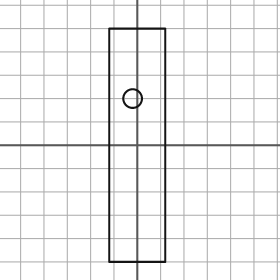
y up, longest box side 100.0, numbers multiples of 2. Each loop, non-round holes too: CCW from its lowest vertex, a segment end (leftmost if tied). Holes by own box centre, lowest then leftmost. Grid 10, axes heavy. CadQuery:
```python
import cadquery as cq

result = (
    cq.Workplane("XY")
    .moveTo(-12.0, -50.0)
    .lineTo(12.0, -50.0)
    .lineTo(12.0, 50.0)
    .lineTo(-12.0, 50.0)
    .close()
    .moveTo(-2.0, 20.0)
    .circle(4.0)
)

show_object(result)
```